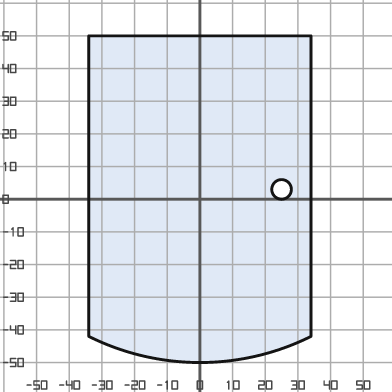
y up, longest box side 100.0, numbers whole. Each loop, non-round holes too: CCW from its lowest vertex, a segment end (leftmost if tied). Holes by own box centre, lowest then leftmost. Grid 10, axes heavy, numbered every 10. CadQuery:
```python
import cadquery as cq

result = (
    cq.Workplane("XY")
    .moveTo(-34.0, -42.0)
    .threePointArc((0.0, -50.0), (34.0, -42.0))
    .lineTo(34.0, 50.0)
    .lineTo(-34.0, 50.0)
    .close()
    .moveTo(25.0, 3.0)
    .circle(3.0)
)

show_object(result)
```